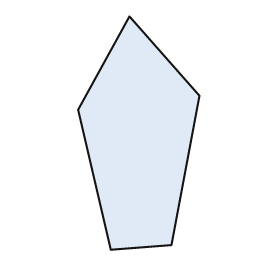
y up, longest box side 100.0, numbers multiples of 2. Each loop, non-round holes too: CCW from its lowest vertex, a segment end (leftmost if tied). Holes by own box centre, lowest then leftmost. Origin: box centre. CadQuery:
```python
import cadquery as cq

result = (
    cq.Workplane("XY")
    .moveTo(-12.0, -50.0)
    .lineTo(14.0, -48.0)
    .lineTo(26.0, 16.0)
    .lineTo(-4.0, 50.0)
    .lineTo(-26.0, 10.0)
    .close()
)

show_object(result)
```